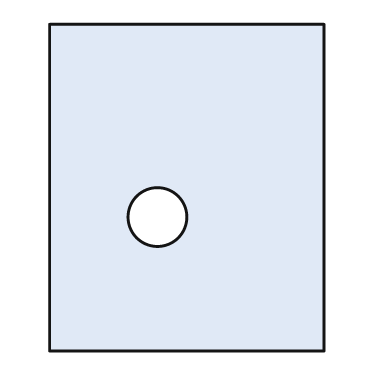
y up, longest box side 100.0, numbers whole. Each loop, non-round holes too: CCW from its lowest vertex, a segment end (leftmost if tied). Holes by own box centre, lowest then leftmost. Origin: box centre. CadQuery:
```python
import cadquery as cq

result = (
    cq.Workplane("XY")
    .moveTo(-42.0, -50.0)
    .lineTo(42.0, -50.0)
    .lineTo(42.0, 50.0)
    .lineTo(-42.0, 50.0)
    .close()
    .moveTo(-9.0, -9.0)
    .circle(9.0)
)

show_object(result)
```